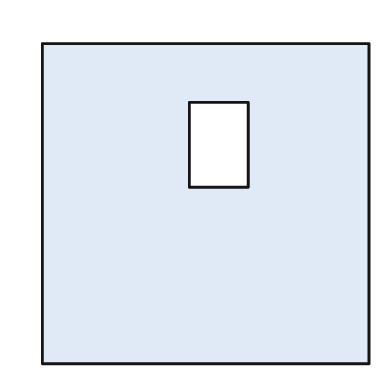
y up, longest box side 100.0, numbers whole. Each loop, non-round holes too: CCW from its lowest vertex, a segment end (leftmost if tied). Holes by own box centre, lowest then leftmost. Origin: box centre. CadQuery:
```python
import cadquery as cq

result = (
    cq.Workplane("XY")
    .moveTo(-50.0, -49.0)
    .lineTo(50.0, -49.0)
    .lineTo(50.0, 49.0)
    .lineTo(-50.0, 49.0)
    .close()
    .moveTo(-5.0, 5.0)
    .lineTo(13.0, 5.0)
    .lineTo(13.0, 31.0)
    .lineTo(-5.0, 31.0)
    .close()
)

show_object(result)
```